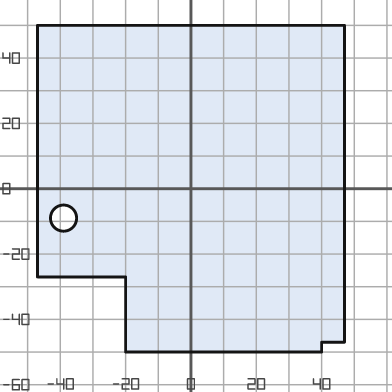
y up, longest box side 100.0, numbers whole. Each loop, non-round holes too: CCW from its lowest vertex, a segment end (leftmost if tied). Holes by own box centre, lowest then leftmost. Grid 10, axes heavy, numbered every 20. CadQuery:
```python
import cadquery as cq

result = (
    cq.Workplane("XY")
    .moveTo(-20.0, -50.0)
    .lineTo(40.0, -50.0)
    .lineTo(40.0, -47.0)
    .lineTo(47.0, -47.0)
    .lineTo(47.0, 50.0)
    .lineTo(-47.0, 50.0)
    .lineTo(-47.0, -27.0)
    .lineTo(-20.0, -27.0)
    .close()
    .moveTo(-39.0, -9.0)
    .circle(4.0)
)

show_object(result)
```